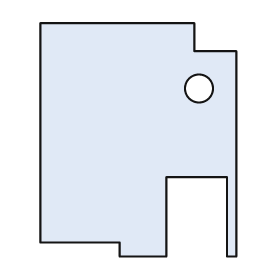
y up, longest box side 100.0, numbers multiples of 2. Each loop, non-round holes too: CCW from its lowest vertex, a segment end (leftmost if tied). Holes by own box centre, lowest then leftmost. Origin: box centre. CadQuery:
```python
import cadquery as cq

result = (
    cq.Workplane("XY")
    .moveTo(-8.0, -50.0)
    .lineTo(12.0, -50.0)
    .lineTo(12.0, -16.0)
    .lineTo(38.0, -16.0)
    .lineTo(38.0, -50.0)
    .lineTo(42.0, -50.0)
    .lineTo(42.0, 38.0)
    .lineTo(24.0, 38.0)
    .lineTo(24.0, 50.0)
    .lineTo(-42.0, 50.0)
    .lineTo(-42.0, -44.0)
    .lineTo(-8.0, -44.0)
    .close()
    .moveTo(26.0, 22.0)
    .circle(6.0)
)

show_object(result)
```